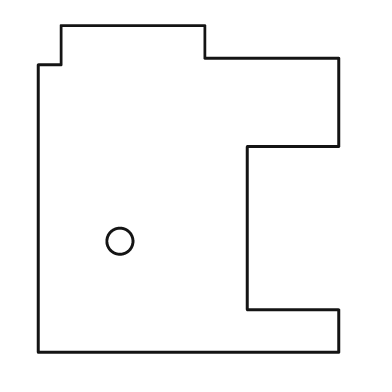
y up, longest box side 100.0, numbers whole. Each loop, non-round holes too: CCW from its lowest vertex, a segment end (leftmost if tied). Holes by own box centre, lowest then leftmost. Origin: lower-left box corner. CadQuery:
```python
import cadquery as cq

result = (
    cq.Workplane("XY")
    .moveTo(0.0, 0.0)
    .lineTo(92.0, 0.0)
    .lineTo(92.0, 13.0)
    .lineTo(64.0, 13.0)
    .lineTo(64.0, 63.0)
    .lineTo(92.0, 63.0)
    .lineTo(92.0, 90.0)
    .lineTo(51.0, 90.0)
    .lineTo(51.0, 100.0)
    .lineTo(7.0, 100.0)
    .lineTo(7.0, 88.0)
    .lineTo(0.0, 88.0)
    .close()
    .moveTo(25.0, 34.0)
    .circle(4.0)
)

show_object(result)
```